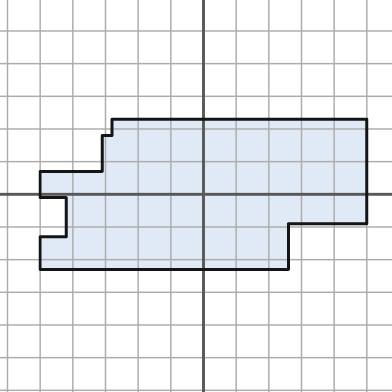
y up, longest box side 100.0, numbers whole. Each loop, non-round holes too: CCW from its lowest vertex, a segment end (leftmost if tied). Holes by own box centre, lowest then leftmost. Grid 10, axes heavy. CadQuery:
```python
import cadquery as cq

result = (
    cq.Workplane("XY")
    .moveTo(-50.0, -23.0)
    .lineTo(26.0, -23.0)
    .lineTo(26.0, -9.0)
    .lineTo(50.0, -9.0)
    .lineTo(50.0, 23.0)
    .lineTo(-28.0, 23.0)
    .lineTo(-28.0, 18.0)
    .lineTo(-31.0, 18.0)
    .lineTo(-31.0, 7.0)
    .lineTo(-50.0, 7.0)
    .lineTo(-50.0, -1.0)
    .lineTo(-42.0, -1.0)
    .lineTo(-42.0, -13.0)
    .lineTo(-50.0, -13.0)
    .close()
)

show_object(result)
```